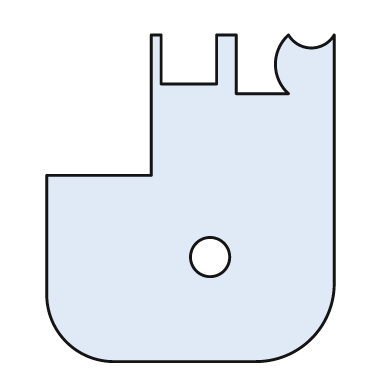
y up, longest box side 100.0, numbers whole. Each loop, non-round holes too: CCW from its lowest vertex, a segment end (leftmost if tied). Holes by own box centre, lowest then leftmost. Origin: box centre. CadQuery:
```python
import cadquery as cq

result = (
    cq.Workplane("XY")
    .moveTo(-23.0, -50.0)
    .lineTo(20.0, -50.0)
    .threePointArc((37.0, -43.0), (44.0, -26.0))
    .lineTo(44.0, 50.0)
    .threePointArc((37.0, 46.0), (30.0, 50.0))
    .threePointArc((26.0, 41.0), (30.0, 32.0))
    .lineTo(14.0, 32.0)
    .lineTo(14.0, 50.0)
    .lineTo(8.0, 50.0)
    .lineTo(8.0, 35.0)
    .lineTo(-9.0, 35.0)
    .lineTo(-9.0, 50.0)
    .lineTo(-12.0, 50.0)
    .lineTo(-12.0, 7.0)
    .lineTo(-44.0, 7.0)
    .lineTo(-44.0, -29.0)
    .threePointArc((-38.0, -44.0), (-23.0, -50.0))
    .close()
    .moveTo(6.0, -18.0)
    .circle(6.0)
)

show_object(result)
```